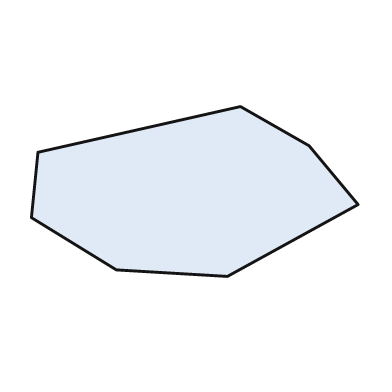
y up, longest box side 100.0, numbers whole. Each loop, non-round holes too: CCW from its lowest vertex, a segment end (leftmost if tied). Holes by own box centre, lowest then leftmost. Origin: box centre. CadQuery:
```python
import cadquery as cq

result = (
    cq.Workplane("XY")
    .moveTo(10.0, -26.0)
    .lineTo(50.0, -4.0)
    .lineTo(35.0, 14.0)
    .lineTo(14.0, 26.0)
    .lineTo(-48.0, 12.0)
    .lineTo(-50.0, -8.0)
    .lineTo(-24.0, -24.0)
    .close()
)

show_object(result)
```